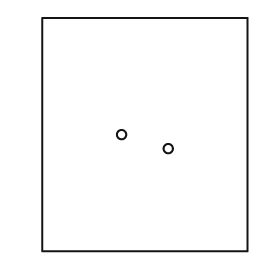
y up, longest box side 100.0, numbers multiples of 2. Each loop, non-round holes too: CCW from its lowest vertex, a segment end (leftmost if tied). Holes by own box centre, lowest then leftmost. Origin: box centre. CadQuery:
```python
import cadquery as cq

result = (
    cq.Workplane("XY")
    .moveTo(-44.0, -50.0)
    .lineTo(44.0, -50.0)
    .lineTo(44.0, 50.0)
    .lineTo(-44.0, 50.0)
    .close()
    .moveTo(10.0, -6.0)
    .circle(2.0)
    .moveTo(-10.0, 0.0)
    .circle(2.0)
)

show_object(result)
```